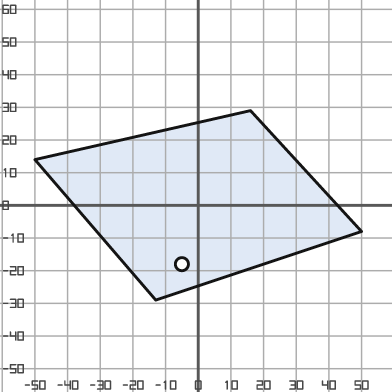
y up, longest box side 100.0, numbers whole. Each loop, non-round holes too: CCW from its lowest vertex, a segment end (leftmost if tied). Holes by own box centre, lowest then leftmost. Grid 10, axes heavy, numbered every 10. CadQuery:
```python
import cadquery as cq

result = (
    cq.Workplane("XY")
    .moveTo(-13.0, -29.0)
    .lineTo(50.0, -8.0)
    .lineTo(16.0, 29.0)
    .lineTo(-50.0, 14.0)
    .close()
    .moveTo(-5.0, -18.0)
    .circle(2.0)
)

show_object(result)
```